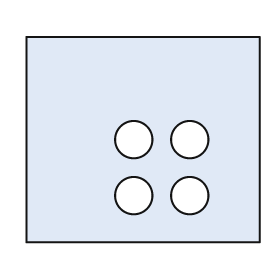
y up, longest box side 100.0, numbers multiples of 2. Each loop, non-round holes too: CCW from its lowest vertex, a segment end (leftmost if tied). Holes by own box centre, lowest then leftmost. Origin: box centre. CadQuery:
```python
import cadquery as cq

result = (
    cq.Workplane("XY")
    .moveTo(-50.0, -44.0)
    .lineTo(50.0, -44.0)
    .lineTo(50.0, 44.0)
    .lineTo(-50.0, 44.0)
    .close()
    .moveTo(-4.0, -24.0)
    .circle(8.0)
    .moveTo(20.0, -24.0)
    .circle(8.0)
    .moveTo(-4.0, 0.0)
    .circle(8.0)
    .moveTo(20.0, 0.0)
    .circle(8.0)
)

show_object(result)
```